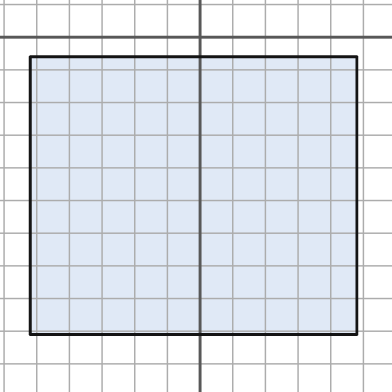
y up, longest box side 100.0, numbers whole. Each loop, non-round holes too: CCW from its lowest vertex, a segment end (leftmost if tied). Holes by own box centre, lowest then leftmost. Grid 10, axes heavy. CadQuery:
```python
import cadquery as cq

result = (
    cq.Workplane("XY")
    .moveTo(-52.0, -91.0)
    .lineTo(48.0, -91.0)
    .lineTo(48.0, -6.0)
    .lineTo(-52.0, -6.0)
    .close()
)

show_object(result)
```